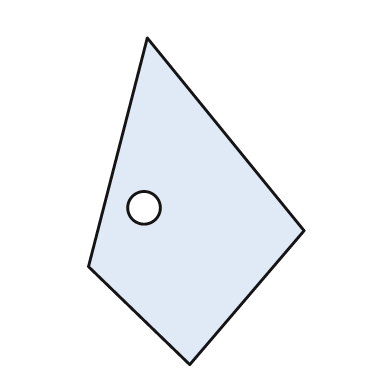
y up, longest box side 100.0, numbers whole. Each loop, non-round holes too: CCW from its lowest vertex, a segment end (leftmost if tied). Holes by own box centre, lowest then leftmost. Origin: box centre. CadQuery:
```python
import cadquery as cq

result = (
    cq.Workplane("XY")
    .moveTo(-2.0, -50.0)
    .lineTo(33.0, -9.0)
    .lineTo(-15.0, 50.0)
    .lineTo(-33.0, -20.0)
    .close()
    .moveTo(-16.0, -2.0)
    .circle(5.0)
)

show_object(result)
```